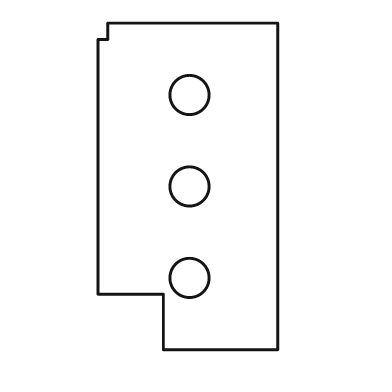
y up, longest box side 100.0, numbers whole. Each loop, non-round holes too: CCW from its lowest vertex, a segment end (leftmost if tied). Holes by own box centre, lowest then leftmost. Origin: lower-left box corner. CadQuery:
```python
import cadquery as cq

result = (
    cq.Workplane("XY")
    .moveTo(20.0, 0.0)
    .lineTo(55.0, 0.0)
    .lineTo(55.0, 100.0)
    .lineTo(3.0, 100.0)
    .lineTo(3.0, 95.0)
    .lineTo(0.0, 95.0)
    .lineTo(0.0, 17.0)
    .lineTo(20.0, 17.0)
    .close()
    .moveTo(28.0, 22.0)
    .circle(6.0)
    .moveTo(28.0, 50.0)
    .circle(6.0)
    .moveTo(28.0, 78.0)
    .circle(6.0)
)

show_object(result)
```